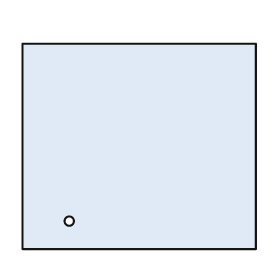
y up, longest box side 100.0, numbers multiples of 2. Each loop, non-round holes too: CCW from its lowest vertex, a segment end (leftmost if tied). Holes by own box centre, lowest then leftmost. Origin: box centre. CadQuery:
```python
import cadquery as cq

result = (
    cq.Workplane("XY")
    .moveTo(-50.0, -44.0)
    .lineTo(50.0, -44.0)
    .lineTo(50.0, 44.0)
    .lineTo(-50.0, 44.0)
    .close()
    .moveTo(-30.0, -32.0)
    .circle(2.0)
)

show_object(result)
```